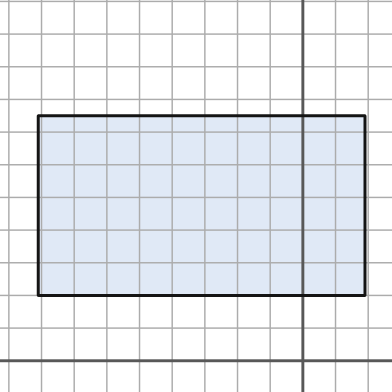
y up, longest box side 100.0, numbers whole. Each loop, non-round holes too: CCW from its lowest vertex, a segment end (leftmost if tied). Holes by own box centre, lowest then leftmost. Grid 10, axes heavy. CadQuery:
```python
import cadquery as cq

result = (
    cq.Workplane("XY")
    .moveTo(-81.0, 20.0)
    .lineTo(19.0, 20.0)
    .lineTo(19.0, 75.0)
    .lineTo(-81.0, 75.0)
    .close()
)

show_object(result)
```